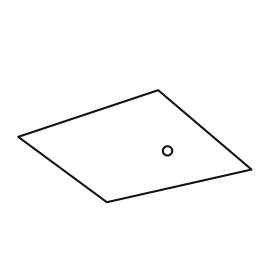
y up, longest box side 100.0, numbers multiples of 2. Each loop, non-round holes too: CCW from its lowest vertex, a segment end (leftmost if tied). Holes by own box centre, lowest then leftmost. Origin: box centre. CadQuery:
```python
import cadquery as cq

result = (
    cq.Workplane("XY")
    .moveTo(-12.0, -24.0)
    .lineTo(50.0, -10.0)
    .lineTo(10.0, 24.0)
    .lineTo(-50.0, 4.0)
    .close()
    .moveTo(14.0, -2.0)
    .circle(2.0)
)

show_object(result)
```